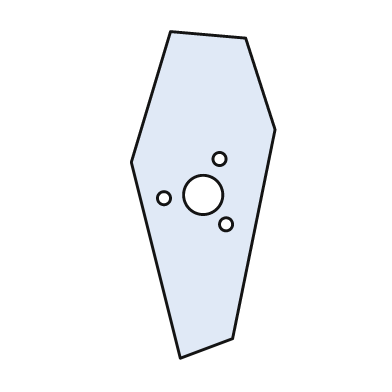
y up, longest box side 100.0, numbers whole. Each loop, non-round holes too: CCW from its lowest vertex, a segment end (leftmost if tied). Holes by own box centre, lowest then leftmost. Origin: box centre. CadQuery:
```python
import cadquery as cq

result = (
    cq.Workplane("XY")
    .moveTo(-7.0, -50.0)
    .lineTo(9.0, -44.0)
    .lineTo(22.0, 20.0)
    .lineTo(13.0, 48.0)
    .lineTo(-10.0, 50.0)
    .lineTo(-22.0, 10.0)
    .close()
    .moveTo(7.0, -9.0)
    .circle(2.0)
    .moveTo(-12.0, -1.0)
    .circle(2.0)
    .moveTo(0.0, 0.0)
    .circle(6.0)
    .moveTo(5.0, 11.0)
    .circle(2.0)
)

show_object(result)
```